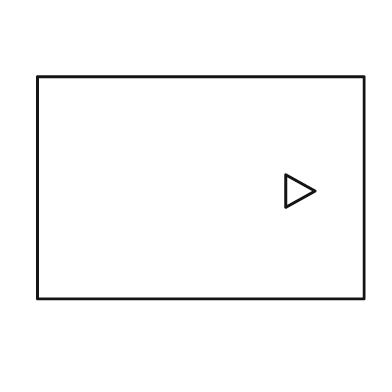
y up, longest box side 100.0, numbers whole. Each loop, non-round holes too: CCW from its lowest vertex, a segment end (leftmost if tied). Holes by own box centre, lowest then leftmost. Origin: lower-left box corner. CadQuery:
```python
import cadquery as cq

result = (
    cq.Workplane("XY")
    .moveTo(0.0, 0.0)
    .lineTo(100.0, 0.0)
    .lineTo(100.0, 68.0)
    .lineTo(0.0, 68.0)
    .close()
    .moveTo(76.0, 28.0)
    .lineTo(85.0, 33.0)
    .lineTo(76.0, 38.0)
    .close()
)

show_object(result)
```